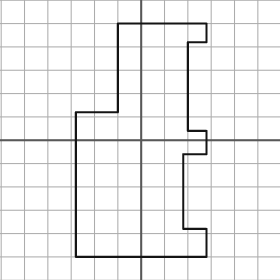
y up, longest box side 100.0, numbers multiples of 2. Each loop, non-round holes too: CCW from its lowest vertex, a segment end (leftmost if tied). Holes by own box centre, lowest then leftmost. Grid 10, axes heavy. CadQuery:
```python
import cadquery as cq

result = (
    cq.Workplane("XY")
    .moveTo(-28.0, -50.0)
    .lineTo(28.0, -50.0)
    .lineTo(28.0, -38.0)
    .lineTo(18.0, -38.0)
    .lineTo(18.0, -6.0)
    .lineTo(28.0, -6.0)
    .lineTo(28.0, 4.0)
    .lineTo(20.0, 4.0)
    .lineTo(20.0, 42.0)
    .lineTo(28.0, 42.0)
    .lineTo(28.0, 50.0)
    .lineTo(-10.0, 50.0)
    .lineTo(-10.0, 12.0)
    .lineTo(-28.0, 12.0)
    .close()
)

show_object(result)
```